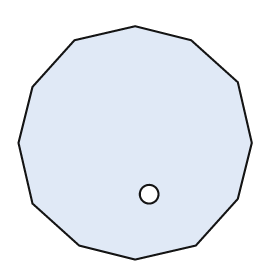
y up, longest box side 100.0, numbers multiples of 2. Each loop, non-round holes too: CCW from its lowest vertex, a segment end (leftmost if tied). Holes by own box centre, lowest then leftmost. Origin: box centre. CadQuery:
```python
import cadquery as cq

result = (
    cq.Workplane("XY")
    .moveTo(0.0, -50.0)
    .lineTo(26.0, -44.0)
    .lineTo(44.0, -24.0)
    .lineTo(50.0, 0.0)
    .lineTo(44.0, 26.0)
    .lineTo(24.0, 44.0)
    .lineTo(0.0, 50.0)
    .lineTo(-26.0, 44.0)
    .lineTo(-44.0, 24.0)
    .lineTo(-50.0, 0.0)
    .lineTo(-44.0, -26.0)
    .lineTo(-24.0, -44.0)
    .close()
    .moveTo(6.0, -22.0)
    .circle(4.0)
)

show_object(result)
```